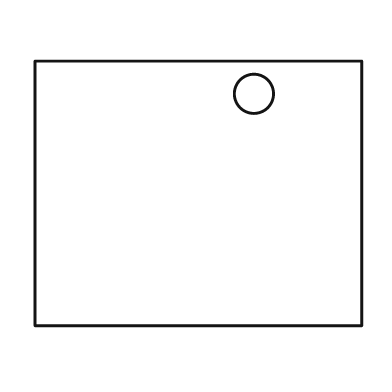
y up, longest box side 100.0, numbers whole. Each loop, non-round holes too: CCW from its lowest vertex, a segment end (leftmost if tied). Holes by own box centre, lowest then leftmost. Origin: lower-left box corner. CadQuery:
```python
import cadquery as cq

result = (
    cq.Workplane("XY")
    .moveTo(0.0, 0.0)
    .lineTo(100.0, 0.0)
    .lineTo(100.0, 81.0)
    .lineTo(0.0, 81.0)
    .close()
    .moveTo(67.0, 71.0)
    .circle(6.0)
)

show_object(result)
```